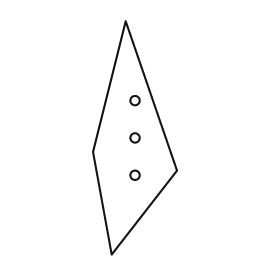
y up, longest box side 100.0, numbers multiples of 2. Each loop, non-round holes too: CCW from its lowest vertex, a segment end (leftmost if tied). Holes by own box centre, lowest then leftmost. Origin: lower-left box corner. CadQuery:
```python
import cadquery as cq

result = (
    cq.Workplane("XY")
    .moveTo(8.0, 0.0)
    .lineTo(36.0, 36.0)
    .lineTo(14.0, 100.0)
    .lineTo(0.0, 44.0)
    .close()
    .moveTo(18.0, 34.0)
    .circle(2.0)
    .moveTo(18.0, 50.0)
    .circle(2.0)
    .moveTo(18.0, 66.0)
    .circle(2.0)
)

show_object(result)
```